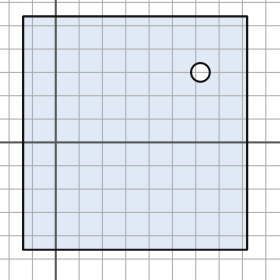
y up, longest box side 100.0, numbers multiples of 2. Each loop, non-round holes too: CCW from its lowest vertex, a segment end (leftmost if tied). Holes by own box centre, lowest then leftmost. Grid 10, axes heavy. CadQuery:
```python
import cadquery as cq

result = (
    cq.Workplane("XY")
    .moveTo(-14.0, -46.0)
    .lineTo(82.0, -46.0)
    .lineTo(82.0, 54.0)
    .lineTo(-14.0, 54.0)
    .close()
    .moveTo(62.0, 30.0)
    .circle(4.0)
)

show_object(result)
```